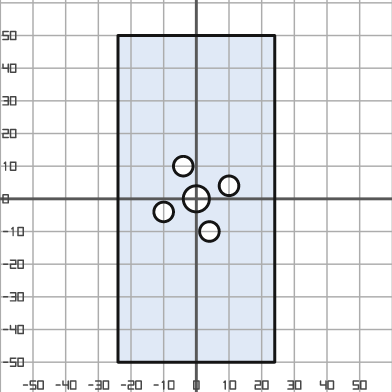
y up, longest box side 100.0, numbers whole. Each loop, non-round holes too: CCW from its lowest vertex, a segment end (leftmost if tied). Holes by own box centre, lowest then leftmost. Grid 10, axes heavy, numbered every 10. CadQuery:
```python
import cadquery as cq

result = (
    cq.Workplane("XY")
    .moveTo(-24.0, -50.0)
    .lineTo(24.0, -50.0)
    .lineTo(24.0, 50.0)
    .lineTo(-24.0, 50.0)
    .close()
    .moveTo(4.0, -10.0)
    .circle(3.0)
    .moveTo(-10.0, -4.0)
    .circle(3.0)
    .moveTo(0.0, 0.0)
    .circle(4.0)
    .moveTo(10.0, 4.0)
    .circle(3.0)
    .moveTo(-4.0, 10.0)
    .circle(3.0)
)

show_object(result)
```